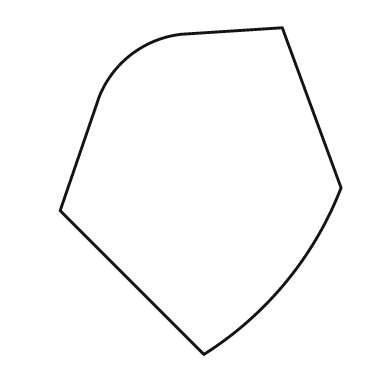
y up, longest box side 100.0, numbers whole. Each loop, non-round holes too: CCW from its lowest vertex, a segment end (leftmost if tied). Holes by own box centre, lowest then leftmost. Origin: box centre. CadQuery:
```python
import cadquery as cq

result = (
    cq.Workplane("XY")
    .moveTo(1.0, -50.0)
    .threePointArc((26.0, -28.0), (43.0, 1.0))
    .lineTo(25.0, 50.0)
    .lineTo(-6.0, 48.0)
    .threePointArc((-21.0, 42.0), (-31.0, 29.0))
    .lineTo(-43.0, -6.0)
    .close()
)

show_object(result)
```